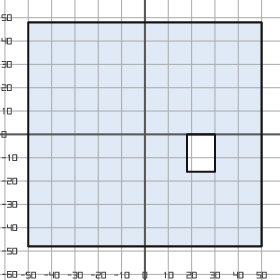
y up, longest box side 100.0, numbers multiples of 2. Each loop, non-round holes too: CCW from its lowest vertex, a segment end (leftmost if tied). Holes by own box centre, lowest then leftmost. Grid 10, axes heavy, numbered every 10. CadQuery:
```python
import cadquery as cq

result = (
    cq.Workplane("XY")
    .moveTo(-50.0, -48.0)
    .lineTo(50.0, -48.0)
    .lineTo(50.0, 48.0)
    .lineTo(-50.0, 48.0)
    .close()
    .moveTo(18.0, -16.0)
    .lineTo(30.0, -16.0)
    .lineTo(30.0, 0.0)
    .lineTo(18.0, 0.0)
    .close()
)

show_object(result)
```